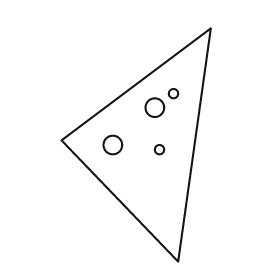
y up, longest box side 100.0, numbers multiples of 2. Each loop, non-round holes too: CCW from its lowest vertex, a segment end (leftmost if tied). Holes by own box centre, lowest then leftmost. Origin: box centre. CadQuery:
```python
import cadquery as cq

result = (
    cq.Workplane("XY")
    .moveTo(18.0, -50.0)
    .lineTo(32.0, 50.0)
    .lineTo(-32.0, 2.0)
    .close()
    .moveTo(10.0, -2.0)
    .circle(2.0)
    .moveTo(-10.0, 0.0)
    .circle(4.0)
    .moveTo(8.0, 16.0)
    .circle(4.0)
    .moveTo(16.0, 22.0)
    .circle(2.0)
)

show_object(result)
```